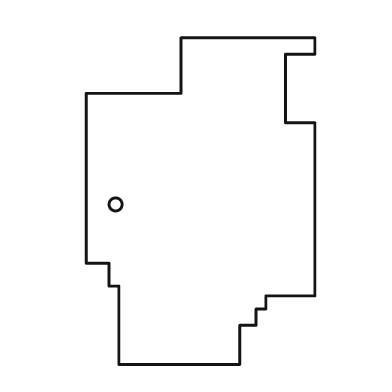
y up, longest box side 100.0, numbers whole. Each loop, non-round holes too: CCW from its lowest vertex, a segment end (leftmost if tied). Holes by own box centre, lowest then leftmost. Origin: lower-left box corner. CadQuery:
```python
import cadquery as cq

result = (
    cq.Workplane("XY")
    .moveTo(10.0, 0.0)
    .lineTo(47.0, 0.0)
    .lineTo(47.0, 12.0)
    .lineTo(52.0, 12.0)
    .lineTo(52.0, 17.0)
    .lineTo(55.0, 17.0)
    .lineTo(55.0, 21.0)
    .lineTo(70.0, 21.0)
    .lineTo(70.0, 74.0)
    .lineTo(61.0, 74.0)
    .lineTo(61.0, 95.0)
    .lineTo(70.0, 95.0)
    .lineTo(70.0, 100.0)
    .lineTo(29.0, 100.0)
    .lineTo(29.0, 83.0)
    .lineTo(0.0, 83.0)
    .lineTo(0.0, 31.0)
    .lineTo(7.0, 31.0)
    .lineTo(7.0, 24.0)
    .lineTo(10.0, 24.0)
    .close()
    .moveTo(9.0, 49.0)
    .circle(2.0)
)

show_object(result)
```